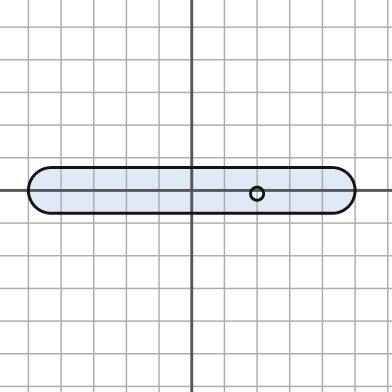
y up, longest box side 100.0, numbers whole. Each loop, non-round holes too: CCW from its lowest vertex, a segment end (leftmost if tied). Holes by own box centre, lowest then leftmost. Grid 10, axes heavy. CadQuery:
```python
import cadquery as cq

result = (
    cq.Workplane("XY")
    .moveTo(-43.0, -7.0)
    .lineTo(43.0, -7.0)
    .threePointArc((50.0, 0.0), (43.0, 7.0))
    .lineTo(-43.0, 7.0)
    .threePointArc((-50.0, 0.0), (-43.0, -7.0))
    .close()
    .moveTo(20.0, -1.0)
    .circle(2.0)
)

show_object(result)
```